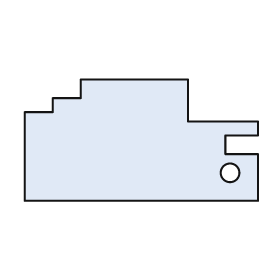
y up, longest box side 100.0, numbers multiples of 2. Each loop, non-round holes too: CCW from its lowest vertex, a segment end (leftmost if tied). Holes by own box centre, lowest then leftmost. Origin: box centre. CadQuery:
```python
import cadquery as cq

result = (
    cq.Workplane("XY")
    .moveTo(-50.0, -26.0)
    .lineTo(50.0, -26.0)
    .lineTo(50.0, -6.0)
    .lineTo(36.0, -6.0)
    .lineTo(36.0, 2.0)
    .lineTo(50.0, 2.0)
    .lineTo(50.0, 8.0)
    .lineTo(20.0, 8.0)
    .lineTo(20.0, 26.0)
    .lineTo(-26.0, 26.0)
    .lineTo(-26.0, 18.0)
    .lineTo(-38.0, 18.0)
    .lineTo(-38.0, 12.0)
    .lineTo(-50.0, 12.0)
    .close()
    .moveTo(38.0, -14.0)
    .circle(4.0)
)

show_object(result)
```